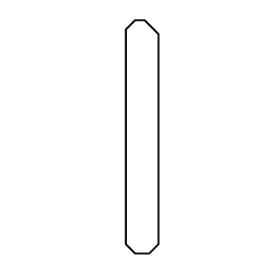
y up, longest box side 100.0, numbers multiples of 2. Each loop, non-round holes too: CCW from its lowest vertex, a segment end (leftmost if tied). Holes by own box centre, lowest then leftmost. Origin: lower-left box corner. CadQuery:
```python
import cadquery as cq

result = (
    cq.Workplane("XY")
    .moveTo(4.0, 0.0)
    .lineTo(10.0, 0.0)
    .lineTo(14.0, 4.0)
    .lineTo(14.0, 94.0)
    .lineTo(8.0, 100.0)
    .lineTo(4.0, 100.0)
    .lineTo(0.0, 96.0)
    .lineTo(0.0, 4.0)
    .close()
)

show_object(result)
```